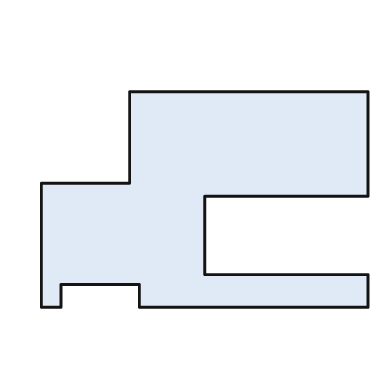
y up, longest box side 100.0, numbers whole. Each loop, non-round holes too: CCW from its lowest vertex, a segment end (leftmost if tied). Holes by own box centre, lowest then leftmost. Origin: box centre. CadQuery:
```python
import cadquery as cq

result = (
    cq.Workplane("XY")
    .moveTo(-50.0, -33.0)
    .lineTo(-44.0, -33.0)
    .lineTo(-44.0, -26.0)
    .lineTo(-20.0, -26.0)
    .lineTo(-20.0, -33.0)
    .lineTo(50.0, -33.0)
    .lineTo(50.0, -23.0)
    .lineTo(0.0, -23.0)
    .lineTo(0.0, 1.0)
    .lineTo(50.0, 1.0)
    .lineTo(50.0, 33.0)
    .lineTo(-23.0, 33.0)
    .lineTo(-23.0, 5.0)
    .lineTo(-50.0, 5.0)
    .close()
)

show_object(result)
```